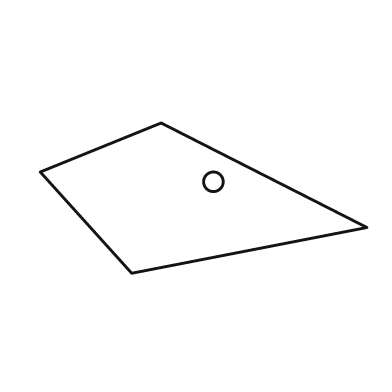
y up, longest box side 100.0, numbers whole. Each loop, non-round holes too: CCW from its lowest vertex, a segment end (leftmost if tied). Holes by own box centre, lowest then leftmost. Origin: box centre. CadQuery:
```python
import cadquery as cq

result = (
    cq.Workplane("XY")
    .moveTo(-22.0, -23.0)
    .lineTo(50.0, -9.0)
    .lineTo(-13.0, 23.0)
    .lineTo(-50.0, 8.0)
    .close()
    .moveTo(3.0, 5.0)
    .circle(3.0)
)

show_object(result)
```